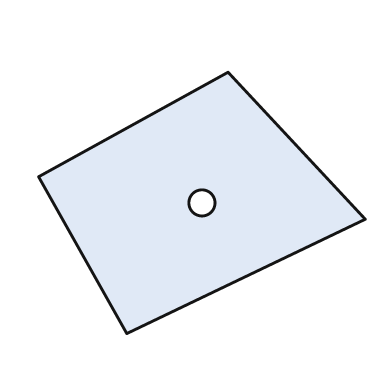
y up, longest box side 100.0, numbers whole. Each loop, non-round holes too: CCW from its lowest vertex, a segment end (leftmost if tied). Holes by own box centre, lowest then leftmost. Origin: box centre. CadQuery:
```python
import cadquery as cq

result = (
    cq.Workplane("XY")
    .moveTo(-23.0, -40.0)
    .lineTo(50.0, -5.0)
    .lineTo(8.0, 40.0)
    .lineTo(-50.0, 8.0)
    .close()
    .moveTo(0.0, 0.0)
    .circle(4.0)
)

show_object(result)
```